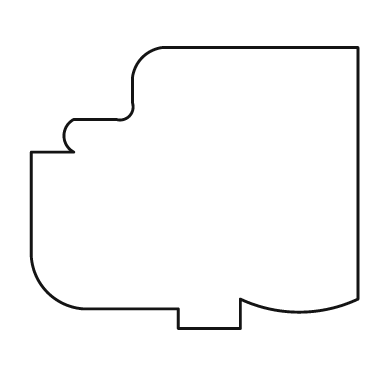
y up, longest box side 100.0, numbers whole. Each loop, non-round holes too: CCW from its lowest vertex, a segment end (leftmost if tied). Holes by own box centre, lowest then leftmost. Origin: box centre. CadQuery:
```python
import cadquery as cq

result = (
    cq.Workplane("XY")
    .moveTo(-5.0, -43.0)
    .lineTo(14.0, -43.0)
    .lineTo(14.0, -34.0)
    .threePointArc((32.0, -38.0), (50.0, -34.0))
    .lineTo(50.0, 43.0)
    .lineTo(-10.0, 43.0)
    .threePointArc((-16.0, 40.0), (-19.0, 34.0))
    .lineTo(-19.0, 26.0)
    .threePointArc((-20.0, 22.0), (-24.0, 21.0))
    .lineTo(-37.0, 21.0)
    .threePointArc((-40.0, 16.0), (-37.0, 11.0))
    .lineTo(-50.0, 11.0)
    .lineTo(-50.0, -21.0)
    .threePointArc((-45.0, -32.0), (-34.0, -37.0))
    .lineTo(-5.0, -37.0)
    .close()
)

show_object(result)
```